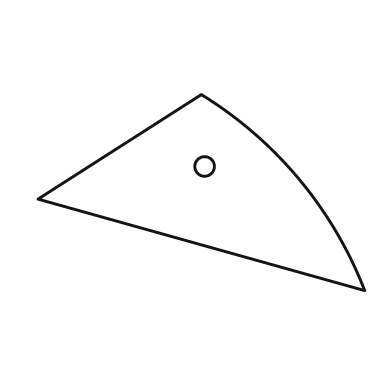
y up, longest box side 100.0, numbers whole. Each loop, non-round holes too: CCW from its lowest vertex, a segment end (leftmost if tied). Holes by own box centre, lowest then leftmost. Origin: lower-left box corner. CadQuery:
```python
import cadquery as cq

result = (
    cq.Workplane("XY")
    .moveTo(100.0, 0.0)
    .threePointArc((80.0, 34.0), (50.0, 60.0))
    .lineTo(0.0, 28.0)
    .close()
    .moveTo(51.0, 38.0)
    .circle(3.0)
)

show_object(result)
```